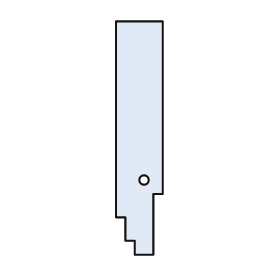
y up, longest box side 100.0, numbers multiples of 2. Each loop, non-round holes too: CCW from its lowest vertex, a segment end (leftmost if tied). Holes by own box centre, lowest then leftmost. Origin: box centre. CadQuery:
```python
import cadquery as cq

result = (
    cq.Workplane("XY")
    .moveTo(-2.0, -50.0)
    .lineTo(6.0, -50.0)
    .lineTo(6.0, -24.0)
    .lineTo(10.0, -24.0)
    .lineTo(10.0, 50.0)
    .lineTo(-10.0, 50.0)
    .lineTo(-10.0, -34.0)
    .lineTo(-6.0, -34.0)
    .lineTo(-6.0, -44.0)
    .lineTo(-2.0, -44.0)
    .close()
    .moveTo(2.0, -18.0)
    .circle(2.0)
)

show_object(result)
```